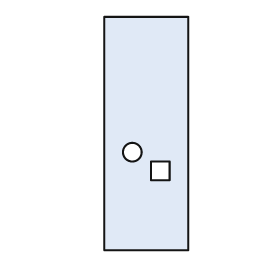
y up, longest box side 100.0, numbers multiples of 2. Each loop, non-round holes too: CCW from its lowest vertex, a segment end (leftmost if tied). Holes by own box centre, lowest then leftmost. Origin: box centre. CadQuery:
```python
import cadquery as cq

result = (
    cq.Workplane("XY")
    .moveTo(-18.0, -50.0)
    .lineTo(18.0, -50.0)
    .lineTo(18.0, 50.0)
    .lineTo(-18.0, 50.0)
    .close()
    .moveTo(2.0, -20.0)
    .lineTo(10.0, -20.0)
    .lineTo(10.0, -12.0)
    .lineTo(2.0, -12.0)
    .close()
    .moveTo(-6.0, -8.0)
    .circle(4.0)
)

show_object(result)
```